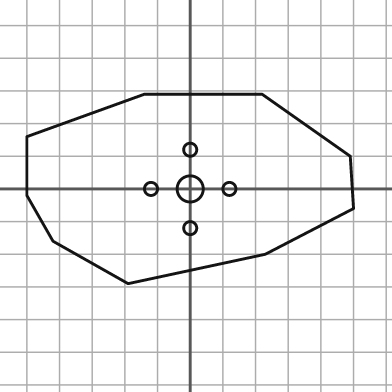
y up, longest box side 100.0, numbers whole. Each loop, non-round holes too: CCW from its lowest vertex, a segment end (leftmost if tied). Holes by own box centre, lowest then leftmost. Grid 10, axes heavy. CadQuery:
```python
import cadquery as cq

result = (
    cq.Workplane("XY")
    .moveTo(-19.0, -29.0)
    .lineTo(23.0, -20.0)
    .lineTo(50.0, -6.0)
    .lineTo(49.0, 10.0)
    .lineTo(22.0, 29.0)
    .lineTo(-14.0, 29.0)
    .lineTo(-50.0, 16.0)
    .lineTo(-50.0, -2.0)
    .lineTo(-42.0, -16.0)
    .close()
    .moveTo(0.0, -12.0)
    .circle(2.0)
    .moveTo(-12.0, 0.0)
    .circle(2.0)
    .moveTo(0.0, 0.0)
    .circle(4.0)
    .moveTo(12.0, 0.0)
    .circle(2.0)
    .moveTo(0.0, 12.0)
    .circle(2.0)
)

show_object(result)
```